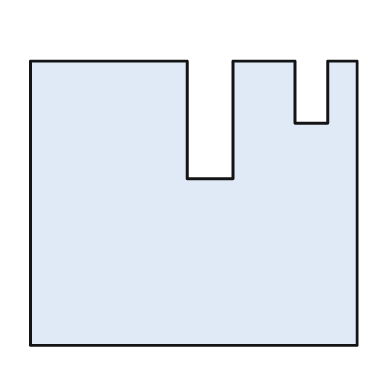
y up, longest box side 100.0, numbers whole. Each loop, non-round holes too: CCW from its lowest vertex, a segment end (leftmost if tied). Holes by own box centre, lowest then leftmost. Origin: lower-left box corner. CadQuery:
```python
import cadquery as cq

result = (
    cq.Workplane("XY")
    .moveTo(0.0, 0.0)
    .lineTo(100.0, 0.0)
    .lineTo(100.0, 87.0)
    .lineTo(91.0, 87.0)
    .lineTo(91.0, 68.0)
    .lineTo(81.0, 68.0)
    .lineTo(81.0, 87.0)
    .lineTo(62.0, 87.0)
    .lineTo(62.0, 51.0)
    .lineTo(48.0, 51.0)
    .lineTo(48.0, 87.0)
    .lineTo(0.0, 87.0)
    .close()
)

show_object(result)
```